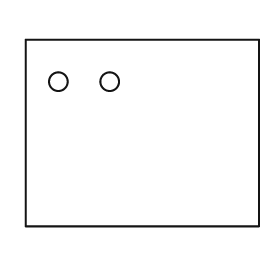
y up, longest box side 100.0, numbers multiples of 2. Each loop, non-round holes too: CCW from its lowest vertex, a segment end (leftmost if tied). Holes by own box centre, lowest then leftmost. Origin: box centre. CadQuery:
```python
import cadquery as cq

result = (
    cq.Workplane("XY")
    .moveTo(-50.0, -40.0)
    .lineTo(50.0, -40.0)
    .lineTo(50.0, 40.0)
    .lineTo(-50.0, 40.0)
    .close()
    .moveTo(-36.0, 22.0)
    .circle(4.0)
    .moveTo(-14.0, 22.0)
    .circle(4.0)
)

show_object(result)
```